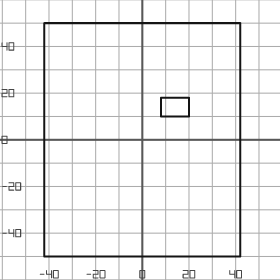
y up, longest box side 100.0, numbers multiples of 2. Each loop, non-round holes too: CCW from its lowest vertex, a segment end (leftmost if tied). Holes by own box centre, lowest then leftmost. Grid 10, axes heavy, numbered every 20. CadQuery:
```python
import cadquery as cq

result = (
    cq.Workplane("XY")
    .moveTo(-42.0, -50.0)
    .lineTo(42.0, -50.0)
    .lineTo(42.0, 50.0)
    .lineTo(-42.0, 50.0)
    .close()
    .moveTo(8.0, 10.0)
    .lineTo(20.0, 10.0)
    .lineTo(20.0, 18.0)
    .lineTo(8.0, 18.0)
    .close()
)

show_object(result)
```